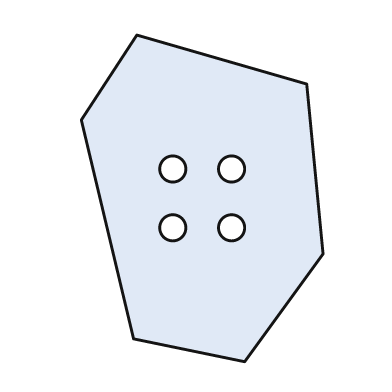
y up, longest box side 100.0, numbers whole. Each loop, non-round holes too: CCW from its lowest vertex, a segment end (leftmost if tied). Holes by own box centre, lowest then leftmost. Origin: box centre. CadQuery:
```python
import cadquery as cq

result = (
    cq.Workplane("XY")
    .moveTo(13.0, -50.0)
    .lineTo(37.0, -17.0)
    .lineTo(32.0, 35.0)
    .lineTo(-20.0, 50.0)
    .lineTo(-37.0, 24.0)
    .lineTo(-21.0, -43.0)
    .close()
    .moveTo(-9.0, -9.0)
    .circle(4.0)
    .moveTo(9.0, -9.0)
    .circle(4.0)
    .moveTo(-9.0, 9.0)
    .circle(4.0)
    .moveTo(9.0, 9.0)
    .circle(4.0)
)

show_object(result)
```